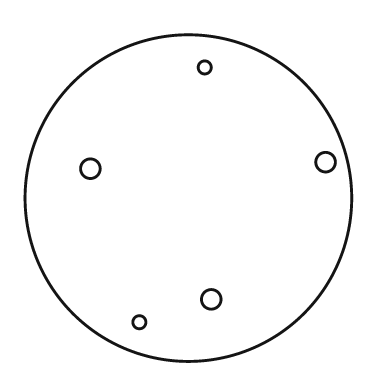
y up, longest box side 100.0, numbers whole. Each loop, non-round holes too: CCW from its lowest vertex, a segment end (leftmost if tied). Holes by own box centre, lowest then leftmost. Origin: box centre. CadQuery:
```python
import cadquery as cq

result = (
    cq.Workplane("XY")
    .moveTo(0.0, 0.0)
    .circle(50.0)
    .moveTo(-15.0, -38.0)
    .circle(2.0)
    .moveTo(7.0, -31.0)
    .circle(3.0)
    .moveTo(-30.0, 9.0)
    .circle(3.0)
    .moveTo(42.0, 11.0)
    .circle(3.0)
    .moveTo(5.0, 40.0)
    .circle(2.0)
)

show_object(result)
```